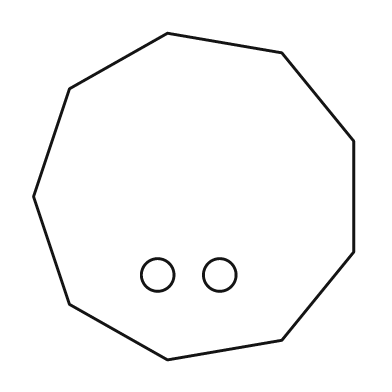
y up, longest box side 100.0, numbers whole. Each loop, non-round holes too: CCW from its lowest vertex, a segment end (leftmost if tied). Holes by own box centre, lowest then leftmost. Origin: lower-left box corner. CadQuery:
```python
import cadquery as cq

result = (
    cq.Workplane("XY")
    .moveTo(41.0, 0.0)
    .lineTo(76.0, 6.0)
    .lineTo(98.0, 33.0)
    .lineTo(98.0, 67.0)
    .lineTo(76.0, 94.0)
    .lineTo(41.0, 100.0)
    .lineTo(11.0, 83.0)
    .lineTo(0.0, 50.0)
    .lineTo(11.0, 17.0)
    .close()
    .moveTo(38.0, 26.0)
    .circle(5.0)
    .moveTo(57.0, 26.0)
    .circle(5.0)
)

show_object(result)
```